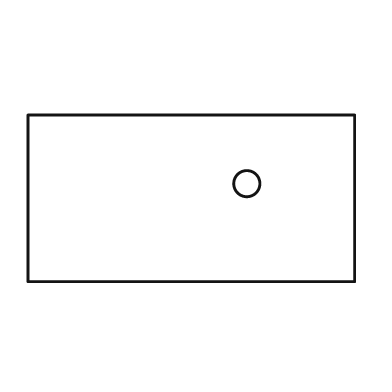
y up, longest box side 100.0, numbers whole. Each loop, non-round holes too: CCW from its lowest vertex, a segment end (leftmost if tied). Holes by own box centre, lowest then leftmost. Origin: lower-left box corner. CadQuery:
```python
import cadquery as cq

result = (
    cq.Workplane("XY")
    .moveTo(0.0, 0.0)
    .lineTo(100.0, 0.0)
    .lineTo(100.0, 51.0)
    .lineTo(0.0, 51.0)
    .close()
    .moveTo(67.0, 30.0)
    .circle(4.0)
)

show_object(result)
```